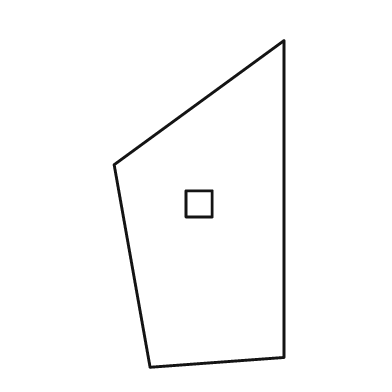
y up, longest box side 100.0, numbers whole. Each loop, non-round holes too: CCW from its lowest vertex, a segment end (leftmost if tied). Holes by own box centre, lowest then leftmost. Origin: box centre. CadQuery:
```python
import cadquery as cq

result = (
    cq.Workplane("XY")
    .moveTo(-15.0, -50.0)
    .lineTo(26.0, -47.0)
    .lineTo(26.0, 50.0)
    .lineTo(-26.0, 12.0)
    .close()
    .moveTo(-4.0, -4.0)
    .lineTo(4.0, -4.0)
    .lineTo(4.0, 4.0)
    .lineTo(-4.0, 4.0)
    .close()
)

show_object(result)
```